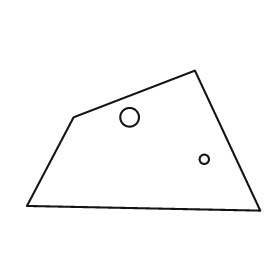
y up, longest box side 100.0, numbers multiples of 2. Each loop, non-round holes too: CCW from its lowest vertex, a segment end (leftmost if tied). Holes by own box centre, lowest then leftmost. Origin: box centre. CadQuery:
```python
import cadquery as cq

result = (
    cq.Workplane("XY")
    .moveTo(50.0, -30.0)
    .lineTo(22.0, 30.0)
    .lineTo(-30.0, 10.0)
    .lineTo(-50.0, -28.0)
    .close()
    .moveTo(26.0, -8.0)
    .circle(2.0)
    .moveTo(-6.0, 10.0)
    .circle(4.0)
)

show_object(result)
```